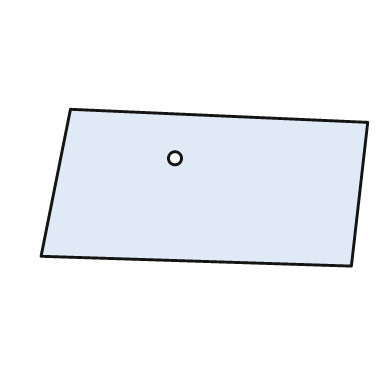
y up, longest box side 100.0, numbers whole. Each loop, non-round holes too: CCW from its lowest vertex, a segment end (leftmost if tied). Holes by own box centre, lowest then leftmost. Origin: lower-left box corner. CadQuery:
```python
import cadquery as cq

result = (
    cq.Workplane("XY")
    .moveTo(95.0, 0.0)
    .lineTo(100.0, 44.0)
    .lineTo(9.0, 48.0)
    .lineTo(0.0, 3.0)
    .close()
    .moveTo(41.0, 33.0)
    .circle(2.0)
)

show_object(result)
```